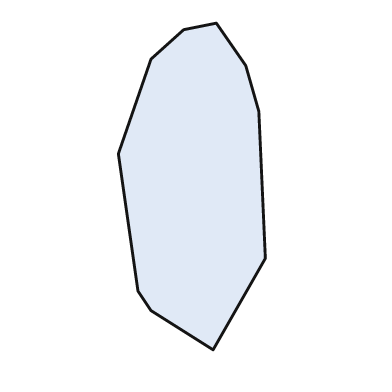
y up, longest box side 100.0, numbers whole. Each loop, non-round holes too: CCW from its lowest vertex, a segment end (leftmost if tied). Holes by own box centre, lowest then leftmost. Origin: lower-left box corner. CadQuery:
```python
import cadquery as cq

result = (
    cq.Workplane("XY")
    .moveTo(29.0, 0.0)
    .lineTo(45.0, 28.0)
    .lineTo(43.0, 73.0)
    .lineTo(39.0, 87.0)
    .lineTo(30.0, 100.0)
    .lineTo(20.0, 98.0)
    .lineTo(10.0, 89.0)
    .lineTo(0.0, 60.0)
    .lineTo(6.0, 18.0)
    .lineTo(10.0, 12.0)
    .close()
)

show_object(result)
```